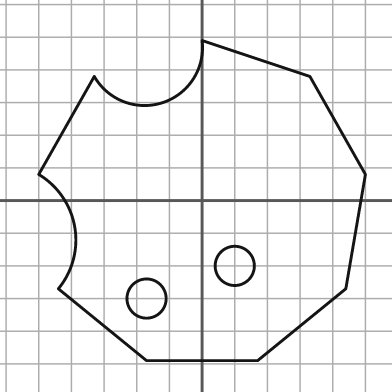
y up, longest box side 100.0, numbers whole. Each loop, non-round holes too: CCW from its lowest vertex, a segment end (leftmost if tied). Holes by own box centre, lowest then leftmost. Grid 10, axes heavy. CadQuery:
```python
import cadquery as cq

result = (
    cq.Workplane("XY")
    .moveTo(-17.0, -49.0)
    .lineTo(17.0, -49.0)
    .lineTo(44.0, -27.0)
    .lineTo(50.0, 8.0)
    .lineTo(33.0, 38.0)
    .lineTo(0.0, 49.0)
    .threePointArc((-12.0, 30.0), (-33.0, 38.0))
    .lineTo(-50.0, 8.0)
    .threePointArc((-39.0, -8.0), (-44.0, -27.0))
    .close()
    .moveTo(-17.0, -30.0)
    .circle(6.0)
    .moveTo(10.0, -20.0)
    .circle(6.0)
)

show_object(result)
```